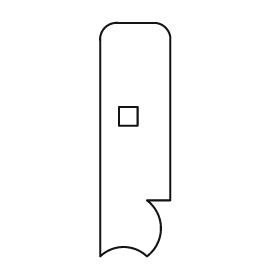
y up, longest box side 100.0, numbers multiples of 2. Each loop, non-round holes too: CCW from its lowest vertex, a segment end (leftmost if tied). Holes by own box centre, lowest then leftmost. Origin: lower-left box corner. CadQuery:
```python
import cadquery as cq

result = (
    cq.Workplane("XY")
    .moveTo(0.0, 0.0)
    .threePointArc((10.0, 4.0), (20.0, 0.0))
    .threePointArc((26.0, 12.0), (20.0, 24.0))
    .lineTo(30.0, 24.0)
    .lineTo(30.0, 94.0)
    .threePointArc((28.0, 98.0), (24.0, 100.0))
    .lineTo(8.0, 100.0)
    .threePointArc((2.0, 98.0), (0.0, 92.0))
    .close()
    .moveTo(8.0, 56.0)
    .lineTo(16.0, 56.0)
    .lineTo(16.0, 64.0)
    .lineTo(8.0, 64.0)
    .close()
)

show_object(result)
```